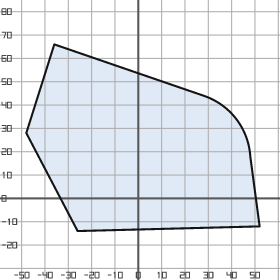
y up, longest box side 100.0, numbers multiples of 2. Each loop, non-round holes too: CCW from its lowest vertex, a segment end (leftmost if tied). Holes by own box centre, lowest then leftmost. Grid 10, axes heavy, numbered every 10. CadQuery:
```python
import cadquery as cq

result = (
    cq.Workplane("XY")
    .moveTo(-26.0, -14.0)
    .lineTo(52.0, -12.0)
    .lineTo(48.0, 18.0)
    .threePointArc((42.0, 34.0), (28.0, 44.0))
    .lineTo(-36.0, 66.0)
    .lineTo(-48.0, 28.0)
    .close()
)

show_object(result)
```